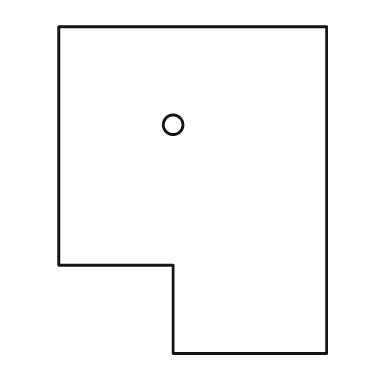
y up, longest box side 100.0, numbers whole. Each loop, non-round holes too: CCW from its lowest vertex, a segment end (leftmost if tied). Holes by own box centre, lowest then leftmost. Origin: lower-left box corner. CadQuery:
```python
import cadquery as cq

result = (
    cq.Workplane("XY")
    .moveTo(35.0, 0.0)
    .lineTo(82.0, 0.0)
    .lineTo(82.0, 100.0)
    .lineTo(0.0, 100.0)
    .lineTo(0.0, 27.0)
    .lineTo(35.0, 27.0)
    .close()
    .moveTo(35.0, 70.0)
    .circle(3.0)
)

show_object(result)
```